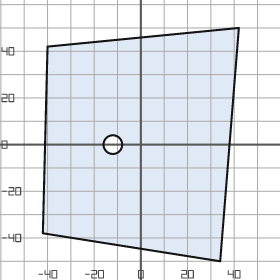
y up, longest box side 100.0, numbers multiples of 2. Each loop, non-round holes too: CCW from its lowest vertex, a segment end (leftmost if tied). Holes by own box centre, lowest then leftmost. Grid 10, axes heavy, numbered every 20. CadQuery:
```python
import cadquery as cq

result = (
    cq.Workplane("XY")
    .moveTo(34.0, -50.0)
    .lineTo(42.0, 50.0)
    .lineTo(-40.0, 42.0)
    .lineTo(-42.0, -38.0)
    .close()
    .moveTo(-12.0, 0.0)
    .circle(4.0)
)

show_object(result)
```